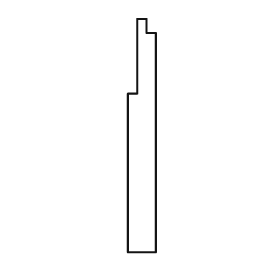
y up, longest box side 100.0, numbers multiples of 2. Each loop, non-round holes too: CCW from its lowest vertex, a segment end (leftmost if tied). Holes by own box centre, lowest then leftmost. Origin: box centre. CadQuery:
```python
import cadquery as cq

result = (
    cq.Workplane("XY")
    .moveTo(-6.0, -50.0)
    .lineTo(6.0, -50.0)
    .lineTo(6.0, 44.0)
    .lineTo(2.0, 44.0)
    .lineTo(2.0, 50.0)
    .lineTo(-2.0, 50.0)
    .lineTo(-2.0, 18.0)
    .lineTo(-6.0, 18.0)
    .close()
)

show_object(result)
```